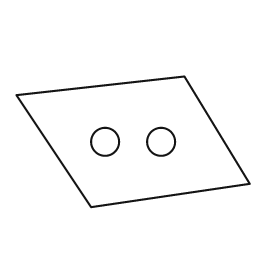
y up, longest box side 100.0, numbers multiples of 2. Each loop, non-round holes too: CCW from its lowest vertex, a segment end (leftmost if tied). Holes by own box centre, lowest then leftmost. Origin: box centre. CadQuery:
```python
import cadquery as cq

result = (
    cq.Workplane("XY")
    .moveTo(-18.0, -28.0)
    .lineTo(50.0, -18.0)
    .lineTo(22.0, 28.0)
    .lineTo(-50.0, 20.0)
    .close()
    .moveTo(-12.0, 0.0)
    .circle(6.0)
    .moveTo(12.0, 0.0)
    .circle(6.0)
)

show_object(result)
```